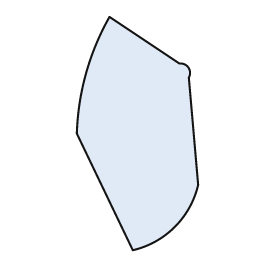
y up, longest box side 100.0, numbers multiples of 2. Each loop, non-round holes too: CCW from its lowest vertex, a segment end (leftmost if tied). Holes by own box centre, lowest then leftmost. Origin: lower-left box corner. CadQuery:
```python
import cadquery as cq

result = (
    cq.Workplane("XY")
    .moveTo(24.0, 0.0)
    .threePointArc((42.0, 10.0), (52.0, 28.0))
    .lineTo(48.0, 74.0)
    .threePointArc((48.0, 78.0), (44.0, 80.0))
    .lineTo(14.0, 100.0)
    .threePointArc((4.0, 76.0), (0.0, 50.0))
    .close()
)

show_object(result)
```